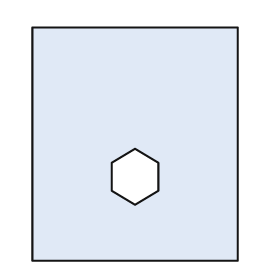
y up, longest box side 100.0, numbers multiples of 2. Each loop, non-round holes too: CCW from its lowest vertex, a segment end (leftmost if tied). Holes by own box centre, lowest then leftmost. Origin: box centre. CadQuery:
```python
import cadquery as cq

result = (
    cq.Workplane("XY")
    .moveTo(-44.0, -50.0)
    .lineTo(44.0, -50.0)
    .lineTo(44.0, 50.0)
    .lineTo(-44.0, 50.0)
    .close()
    .moveTo(0.0, -26.0)
    .lineTo(10.0, -20.0)
    .lineTo(10.0, -8.0)
    .lineTo(0.0, -2.0)
    .lineTo(-10.0, -8.0)
    .lineTo(-10.0, -20.0)
    .close()
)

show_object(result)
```